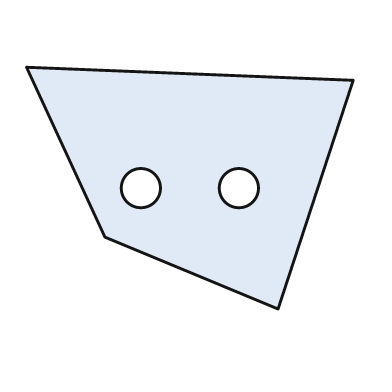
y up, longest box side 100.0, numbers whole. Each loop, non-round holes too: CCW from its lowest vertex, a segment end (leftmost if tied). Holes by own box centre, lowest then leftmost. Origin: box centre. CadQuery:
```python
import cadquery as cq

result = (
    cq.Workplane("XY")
    .moveTo(27.0, -37.0)
    .lineTo(50.0, 33.0)
    .lineTo(-50.0, 37.0)
    .lineTo(-26.0, -15.0)
    .close()
    .moveTo(-15.0, 0.0)
    .circle(6.0)
    .moveTo(15.0, 0.0)
    .circle(6.0)
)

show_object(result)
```